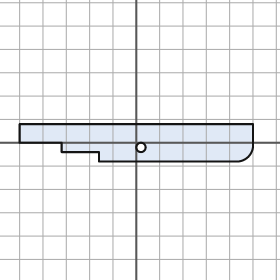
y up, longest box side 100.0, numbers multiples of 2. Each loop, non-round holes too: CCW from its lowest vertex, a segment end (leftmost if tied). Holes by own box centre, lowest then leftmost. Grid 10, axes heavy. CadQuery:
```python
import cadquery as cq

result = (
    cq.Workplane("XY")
    .moveTo(-16.0, -8.0)
    .lineTo(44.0, -8.0)
    .threePointArc((48.0, -6.0), (50.0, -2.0))
    .lineTo(50.0, 8.0)
    .lineTo(-50.0, 8.0)
    .lineTo(-50.0, 0.0)
    .lineTo(-32.0, 0.0)
    .lineTo(-32.0, -4.0)
    .lineTo(-16.0, -4.0)
    .close()
    .moveTo(2.0, -2.0)
    .circle(2.0)
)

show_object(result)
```